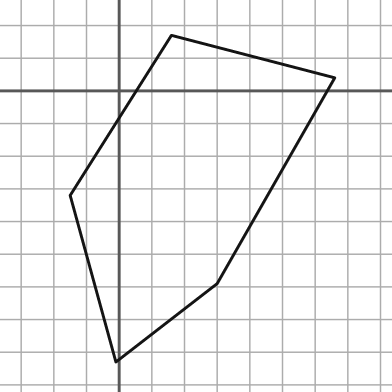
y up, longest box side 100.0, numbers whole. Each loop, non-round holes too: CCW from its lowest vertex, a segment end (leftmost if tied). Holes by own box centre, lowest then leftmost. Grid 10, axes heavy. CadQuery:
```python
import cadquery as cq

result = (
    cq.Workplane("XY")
    .moveTo(-1.0, -83.0)
    .lineTo(30.0, -59.0)
    .lineTo(66.0, 4.0)
    .lineTo(16.0, 17.0)
    .lineTo(-15.0, -32.0)
    .close()
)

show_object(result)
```